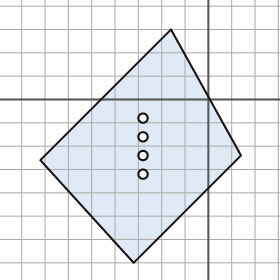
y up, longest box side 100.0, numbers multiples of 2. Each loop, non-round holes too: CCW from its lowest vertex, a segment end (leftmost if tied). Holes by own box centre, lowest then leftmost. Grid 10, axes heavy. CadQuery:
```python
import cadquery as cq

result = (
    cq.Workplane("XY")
    .moveTo(-32.0, -70.0)
    .lineTo(14.0, -24.0)
    .lineTo(-16.0, 30.0)
    .lineTo(-72.0, -26.0)
    .close()
    .moveTo(-28.0, -32.0)
    .circle(2.0)
    .moveTo(-28.0, -24.0)
    .circle(2.0)
    .moveTo(-28.0, -16.0)
    .circle(2.0)
    .moveTo(-28.0, -8.0)
    .circle(2.0)
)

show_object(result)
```